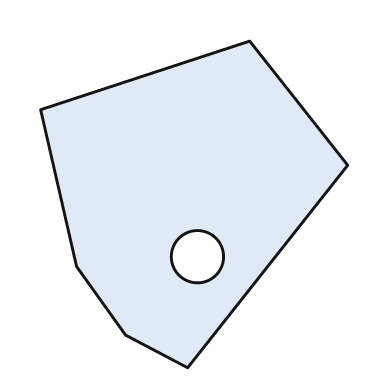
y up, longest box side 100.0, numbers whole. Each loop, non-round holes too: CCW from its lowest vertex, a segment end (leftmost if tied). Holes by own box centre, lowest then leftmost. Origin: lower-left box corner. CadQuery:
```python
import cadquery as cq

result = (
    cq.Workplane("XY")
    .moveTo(45.0, 0.0)
    .lineTo(94.0, 62.0)
    .lineTo(64.0, 100.0)
    .lineTo(0.0, 79.0)
    .lineTo(11.0, 31.0)
    .lineTo(26.0, 10.0)
    .close()
    .moveTo(48.0, 34.0)
    .circle(8.0)
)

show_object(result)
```